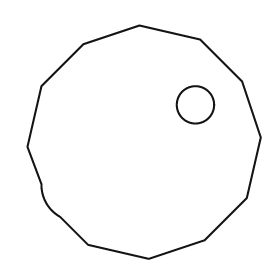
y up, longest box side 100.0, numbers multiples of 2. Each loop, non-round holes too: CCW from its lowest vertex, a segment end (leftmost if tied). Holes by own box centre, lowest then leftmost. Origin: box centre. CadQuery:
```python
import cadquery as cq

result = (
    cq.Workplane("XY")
    .moveTo(2.0, -50.0)
    .lineTo(26.0, -42.0)
    .lineTo(44.0, -24.0)
    .lineTo(50.0, 2.0)
    .lineTo(42.0, 26.0)
    .lineTo(24.0, 44.0)
    .lineTo(-2.0, 50.0)
    .lineTo(-26.0, 42.0)
    .lineTo(-44.0, 24.0)
    .lineTo(-50.0, -2.0)
    .lineTo(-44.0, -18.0)
    .threePointArc((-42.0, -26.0), (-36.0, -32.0))
    .lineTo(-24.0, -44.0)
    .close()
    .moveTo(22.0, 16.0)
    .circle(8.0)
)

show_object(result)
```